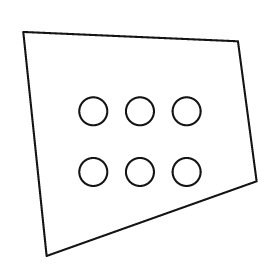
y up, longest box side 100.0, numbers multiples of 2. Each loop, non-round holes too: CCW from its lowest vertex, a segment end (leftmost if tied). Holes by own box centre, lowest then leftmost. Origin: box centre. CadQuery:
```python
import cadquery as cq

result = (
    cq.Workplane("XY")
    .moveTo(-40.0, -48.0)
    .lineTo(50.0, -16.0)
    .lineTo(42.0, 44.0)
    .lineTo(-50.0, 48.0)
    .close()
    .moveTo(-20.0, -12.0)
    .circle(6.0)
    .moveTo(0.0, -12.0)
    .circle(6.0)
    .moveTo(20.0, -12.0)
    .circle(6.0)
    .moveTo(-20.0, 14.0)
    .circle(6.0)
    .moveTo(0.0, 14.0)
    .circle(6.0)
    .moveTo(20.0, 14.0)
    .circle(6.0)
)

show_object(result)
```